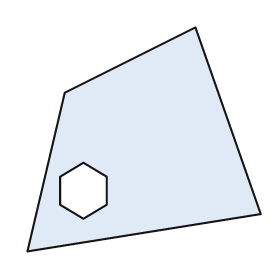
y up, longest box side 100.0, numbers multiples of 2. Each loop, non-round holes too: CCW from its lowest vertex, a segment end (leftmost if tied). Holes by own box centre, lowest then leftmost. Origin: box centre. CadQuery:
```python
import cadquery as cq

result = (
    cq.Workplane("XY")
    .moveTo(-50.0, -48.0)
    .lineTo(50.0, -32.0)
    .lineTo(22.0, 48.0)
    .lineTo(-34.0, 20.0)
    .close()
    .moveTo(-26.0, -34.0)
    .lineTo(-16.0, -28.0)
    .lineTo(-16.0, -16.0)
    .lineTo(-26.0, -10.0)
    .lineTo(-36.0, -16.0)
    .lineTo(-36.0, -28.0)
    .close()
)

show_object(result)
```